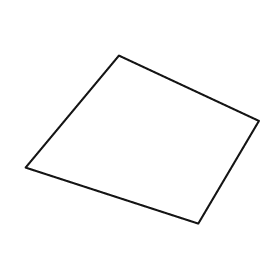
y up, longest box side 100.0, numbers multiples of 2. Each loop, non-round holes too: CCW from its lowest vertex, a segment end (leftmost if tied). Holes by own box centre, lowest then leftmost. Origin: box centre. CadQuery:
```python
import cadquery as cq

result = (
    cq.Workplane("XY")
    .moveTo(24.0, -36.0)
    .lineTo(50.0, 8.0)
    .lineTo(-10.0, 36.0)
    .lineTo(-50.0, -12.0)
    .close()
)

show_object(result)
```